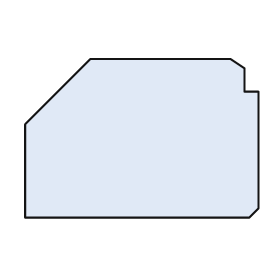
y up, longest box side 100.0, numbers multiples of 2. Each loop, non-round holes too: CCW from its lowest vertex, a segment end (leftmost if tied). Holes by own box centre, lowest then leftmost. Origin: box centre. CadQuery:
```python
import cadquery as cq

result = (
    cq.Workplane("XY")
    .moveTo(-50.0, -34.0)
    .lineTo(46.0, -34.0)
    .lineTo(50.0, -30.0)
    .lineTo(50.0, 20.0)
    .lineTo(44.0, 20.0)
    .lineTo(44.0, 30.0)
    .lineTo(38.0, 34.0)
    .lineTo(-22.0, 34.0)
    .lineTo(-50.0, 6.0)
    .close()
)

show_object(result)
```